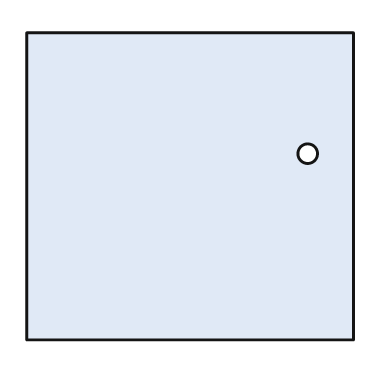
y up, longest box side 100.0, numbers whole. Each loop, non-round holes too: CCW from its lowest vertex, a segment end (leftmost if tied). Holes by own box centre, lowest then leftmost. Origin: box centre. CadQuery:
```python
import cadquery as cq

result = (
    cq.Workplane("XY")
    .moveTo(-50.0, -47.0)
    .lineTo(50.0, -47.0)
    .lineTo(50.0, 47.0)
    .lineTo(-50.0, 47.0)
    .close()
    .moveTo(36.0, 10.0)
    .circle(3.0)
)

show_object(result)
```